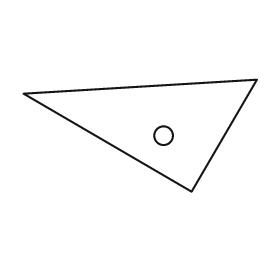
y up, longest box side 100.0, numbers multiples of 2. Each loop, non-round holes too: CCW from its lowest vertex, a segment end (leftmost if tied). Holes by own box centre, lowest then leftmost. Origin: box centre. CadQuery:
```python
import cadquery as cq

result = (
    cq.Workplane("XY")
    .moveTo(22.0, -24.0)
    .lineTo(50.0, 24.0)
    .lineTo(-50.0, 18.0)
    .close()
    .moveTo(10.0, 0.0)
    .circle(4.0)
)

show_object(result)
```